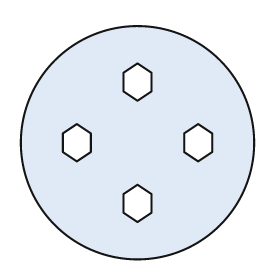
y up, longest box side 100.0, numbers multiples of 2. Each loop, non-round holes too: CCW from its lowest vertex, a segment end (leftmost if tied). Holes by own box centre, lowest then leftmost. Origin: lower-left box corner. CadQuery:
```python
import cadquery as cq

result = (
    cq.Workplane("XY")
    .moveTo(50.0, 50.0)
    .circle(50.0)
    .moveTo(50.0, 16.0)
    .lineTo(56.0, 20.0)
    .lineTo(56.0, 28.0)
    .lineTo(50.0, 32.0)
    .lineTo(44.0, 28.0)
    .lineTo(44.0, 20.0)
    .close()
    .moveTo(24.0, 42.0)
    .lineTo(30.0, 46.0)
    .lineTo(30.0, 54.0)
    .lineTo(24.0, 58.0)
    .lineTo(18.0, 54.0)
    .lineTo(18.0, 46.0)
    .close()
    .moveTo(76.0, 42.0)
    .lineTo(82.0, 46.0)
    .lineTo(82.0, 54.0)
    .lineTo(76.0, 58.0)
    .lineTo(70.0, 54.0)
    .lineTo(70.0, 46.0)
    .close()
    .moveTo(50.0, 68.0)
    .lineTo(56.0, 72.0)
    .lineTo(56.0, 80.0)
    .lineTo(50.0, 84.0)
    .lineTo(44.0, 80.0)
    .lineTo(44.0, 72.0)
    .close()
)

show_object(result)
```